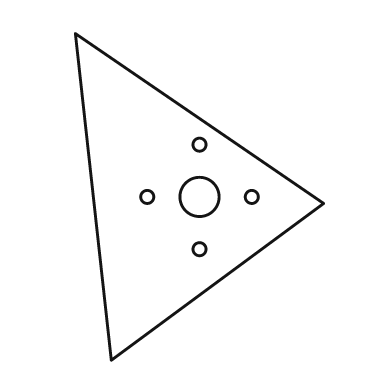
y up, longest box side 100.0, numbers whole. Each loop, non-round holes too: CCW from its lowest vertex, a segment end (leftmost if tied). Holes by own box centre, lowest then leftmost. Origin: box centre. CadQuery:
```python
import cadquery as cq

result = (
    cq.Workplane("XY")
    .moveTo(-27.0, -50.0)
    .lineTo(38.0, -2.0)
    .lineTo(-38.0, 50.0)
    .close()
    .moveTo(0.0, -16.0)
    .circle(2.0)
    .moveTo(-16.0, 0.0)
    .circle(2.0)
    .moveTo(0.0, 0.0)
    .circle(6.0)
    .moveTo(16.0, 0.0)
    .circle(2.0)
    .moveTo(0.0, 16.0)
    .circle(2.0)
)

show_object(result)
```